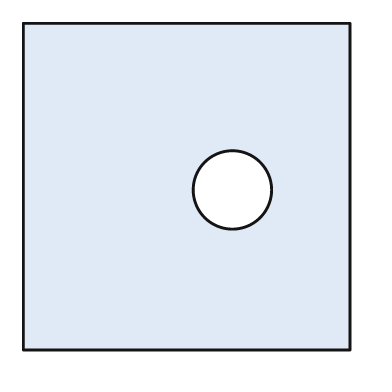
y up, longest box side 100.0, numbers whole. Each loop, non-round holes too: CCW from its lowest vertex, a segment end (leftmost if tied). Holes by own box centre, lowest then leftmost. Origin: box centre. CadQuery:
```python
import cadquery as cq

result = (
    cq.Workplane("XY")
    .moveTo(-50.0, -50.0)
    .lineTo(50.0, -50.0)
    .lineTo(50.0, 50.0)
    .lineTo(-50.0, 50.0)
    .close()
    .moveTo(14.0, -1.0)
    .circle(12.0)
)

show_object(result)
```